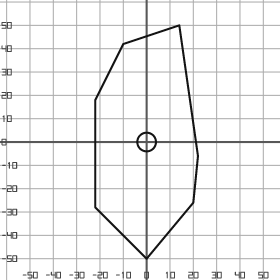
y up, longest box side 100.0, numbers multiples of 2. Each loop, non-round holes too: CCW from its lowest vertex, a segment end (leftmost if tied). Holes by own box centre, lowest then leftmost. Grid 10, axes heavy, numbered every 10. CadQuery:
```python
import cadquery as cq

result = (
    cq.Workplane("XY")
    .moveTo(0.0, -50.0)
    .lineTo(20.0, -26.0)
    .lineTo(22.0, -6.0)
    .lineTo(14.0, 50.0)
    .lineTo(-10.0, 42.0)
    .lineTo(-22.0, 18.0)
    .lineTo(-22.0, -28.0)
    .close()
    .moveTo(0.0, 0.0)
    .circle(4.0)
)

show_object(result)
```